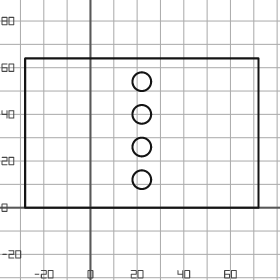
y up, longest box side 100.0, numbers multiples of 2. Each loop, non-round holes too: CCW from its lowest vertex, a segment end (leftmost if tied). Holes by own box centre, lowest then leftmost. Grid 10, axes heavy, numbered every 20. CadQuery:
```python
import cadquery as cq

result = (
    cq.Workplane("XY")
    .moveTo(-28.0, 0.0)
    .lineTo(72.0, 0.0)
    .lineTo(72.0, 64.0)
    .lineTo(-28.0, 64.0)
    .close()
    .moveTo(22.0, 12.0)
    .circle(4.0)
    .moveTo(22.0, 26.0)
    .circle(4.0)
    .moveTo(22.0, 40.0)
    .circle(4.0)
    .moveTo(22.0, 54.0)
    .circle(4.0)
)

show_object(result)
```